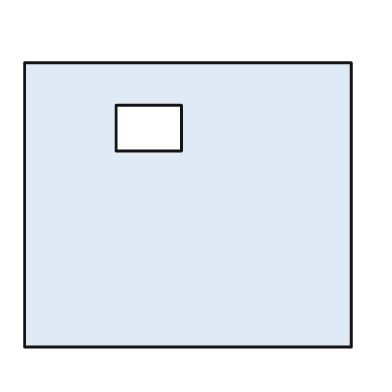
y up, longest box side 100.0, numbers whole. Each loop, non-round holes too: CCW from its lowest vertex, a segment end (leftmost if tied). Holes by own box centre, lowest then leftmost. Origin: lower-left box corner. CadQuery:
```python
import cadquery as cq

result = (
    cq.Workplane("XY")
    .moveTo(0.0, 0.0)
    .lineTo(100.0, 0.0)
    .lineTo(100.0, 87.0)
    .lineTo(0.0, 87.0)
    .close()
    .moveTo(28.0, 60.0)
    .lineTo(48.0, 60.0)
    .lineTo(48.0, 74.0)
    .lineTo(28.0, 74.0)
    .close()
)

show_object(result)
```